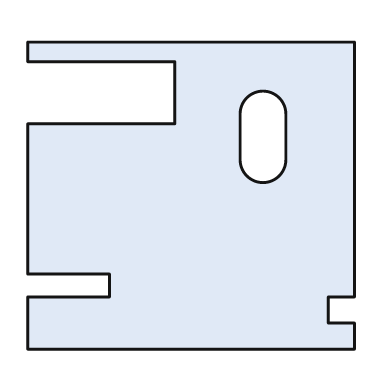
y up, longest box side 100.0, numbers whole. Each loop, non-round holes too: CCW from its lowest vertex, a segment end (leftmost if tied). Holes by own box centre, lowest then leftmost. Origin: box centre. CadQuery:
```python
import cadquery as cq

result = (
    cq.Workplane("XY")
    .moveTo(-50.0, -47.0)
    .lineTo(50.0, -47.0)
    .lineTo(50.0, -39.0)
    .lineTo(42.0, -39.0)
    .lineTo(42.0, -31.0)
    .lineTo(50.0, -31.0)
    .lineTo(50.0, 47.0)
    .lineTo(-50.0, 47.0)
    .lineTo(-50.0, 41.0)
    .lineTo(-5.0, 41.0)
    .lineTo(-5.0, 22.0)
    .lineTo(-50.0, 22.0)
    .lineTo(-50.0, -24.0)
    .lineTo(-25.0, -24.0)
    .lineTo(-25.0, -31.0)
    .lineTo(-50.0, -31.0)
    .close()
    .moveTo(15.0, 11.0)
    .threePointArc((22.0, 4.0), (29.0, 11.0))
    .lineTo(29.0, 25.0)
    .threePointArc((22.0, 32.0), (15.0, 25.0))
    .close()
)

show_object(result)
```